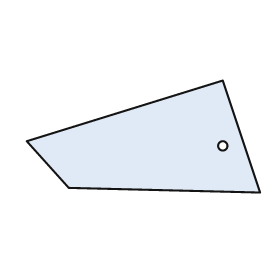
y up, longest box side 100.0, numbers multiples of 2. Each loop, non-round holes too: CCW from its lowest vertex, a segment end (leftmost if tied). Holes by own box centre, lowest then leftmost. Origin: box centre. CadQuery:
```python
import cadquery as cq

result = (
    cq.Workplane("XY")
    .moveTo(50.0, -24.0)
    .lineTo(34.0, 24.0)
    .lineTo(-50.0, -2.0)
    .lineTo(-32.0, -22.0)
    .close()
    .moveTo(34.0, -4.0)
    .circle(2.0)
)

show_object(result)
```